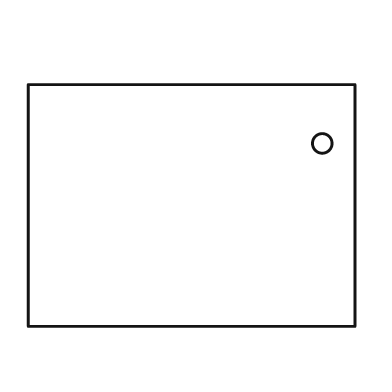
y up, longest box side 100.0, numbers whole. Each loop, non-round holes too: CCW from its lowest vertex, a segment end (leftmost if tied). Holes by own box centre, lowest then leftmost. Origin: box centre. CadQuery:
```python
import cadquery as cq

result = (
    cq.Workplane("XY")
    .moveTo(-50.0, -37.0)
    .lineTo(50.0, -37.0)
    .lineTo(50.0, 37.0)
    .lineTo(-50.0, 37.0)
    .close()
    .moveTo(40.0, 19.0)
    .circle(3.0)
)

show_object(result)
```